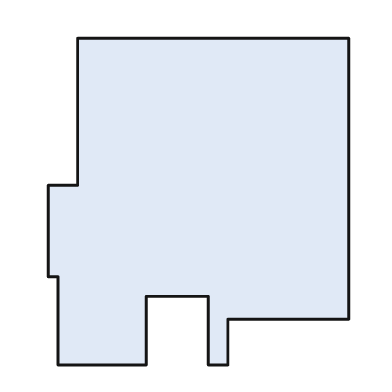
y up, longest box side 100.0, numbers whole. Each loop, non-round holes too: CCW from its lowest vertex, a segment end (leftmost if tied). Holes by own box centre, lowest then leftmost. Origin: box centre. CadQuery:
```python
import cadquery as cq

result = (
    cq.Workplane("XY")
    .moveTo(-43.0, -50.0)
    .lineTo(-16.0, -50.0)
    .lineTo(-16.0, -29.0)
    .lineTo(3.0, -29.0)
    .lineTo(3.0, -50.0)
    .lineTo(9.0, -50.0)
    .lineTo(9.0, -36.0)
    .lineTo(46.0, -36.0)
    .lineTo(46.0, 50.0)
    .lineTo(-37.0, 50.0)
    .lineTo(-37.0, 5.0)
    .lineTo(-46.0, 5.0)
    .lineTo(-46.0, -23.0)
    .lineTo(-43.0, -23.0)
    .close()
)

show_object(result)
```